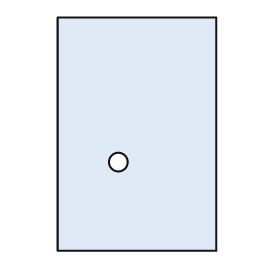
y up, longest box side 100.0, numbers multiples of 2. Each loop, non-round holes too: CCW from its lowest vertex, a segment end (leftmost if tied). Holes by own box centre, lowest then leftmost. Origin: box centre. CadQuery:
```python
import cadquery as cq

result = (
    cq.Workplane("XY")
    .moveTo(-34.0, -50.0)
    .lineTo(34.0, -50.0)
    .lineTo(34.0, 50.0)
    .lineTo(-34.0, 50.0)
    .close()
    .moveTo(-8.0, -12.0)
    .circle(4.0)
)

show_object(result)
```